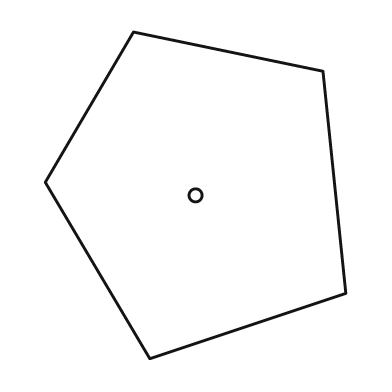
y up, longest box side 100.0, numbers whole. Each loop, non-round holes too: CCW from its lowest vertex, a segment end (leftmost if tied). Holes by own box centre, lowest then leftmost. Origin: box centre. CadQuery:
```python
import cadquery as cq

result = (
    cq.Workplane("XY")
    .moveTo(-14.0, -50.0)
    .lineTo(46.0, -30.0)
    .lineTo(39.0, 38.0)
    .lineTo(-19.0, 50.0)
    .lineTo(-46.0, 4.0)
    .close()
    .moveTo(0.0, 0.0)
    .circle(2.0)
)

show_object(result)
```